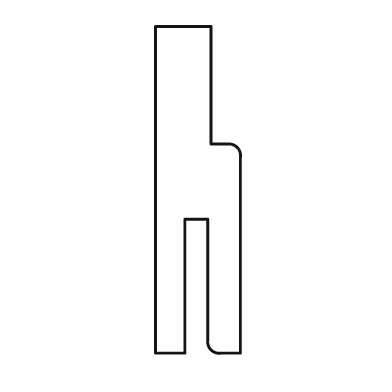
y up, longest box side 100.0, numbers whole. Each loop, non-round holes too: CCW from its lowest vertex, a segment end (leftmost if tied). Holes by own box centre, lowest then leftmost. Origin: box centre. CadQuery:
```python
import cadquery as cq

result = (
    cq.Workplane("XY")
    .moveTo(-13.0, -50.0)
    .lineTo(-4.0, -50.0)
    .lineTo(-4.0, -9.0)
    .lineTo(3.0, -9.0)
    .lineTo(3.0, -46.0)
    .threePointArc((4.0, -49.0), (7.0, -50.0))
    .lineTo(13.0, -50.0)
    .lineTo(13.0, 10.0)
    .threePointArc((12.0, 13.0), (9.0, 14.0))
    .lineTo(4.0, 14.0)
    .lineTo(4.0, 50.0)
    .lineTo(-13.0, 50.0)
    .close()
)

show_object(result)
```